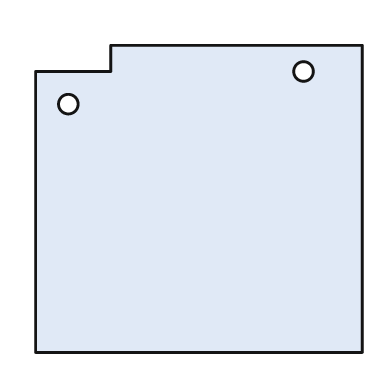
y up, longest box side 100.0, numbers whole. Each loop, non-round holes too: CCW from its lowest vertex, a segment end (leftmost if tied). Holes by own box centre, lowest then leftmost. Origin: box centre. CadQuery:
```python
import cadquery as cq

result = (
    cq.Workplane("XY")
    .moveTo(-50.0, -47.0)
    .lineTo(50.0, -47.0)
    .lineTo(50.0, 47.0)
    .lineTo(-27.0, 47.0)
    .lineTo(-27.0, 39.0)
    .lineTo(-50.0, 39.0)
    .close()
    .moveTo(-40.0, 29.0)
    .circle(3.0)
    .moveTo(32.0, 39.0)
    .circle(3.0)
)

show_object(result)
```